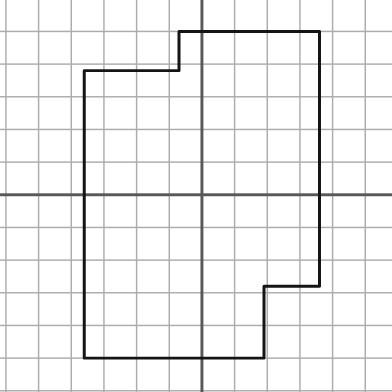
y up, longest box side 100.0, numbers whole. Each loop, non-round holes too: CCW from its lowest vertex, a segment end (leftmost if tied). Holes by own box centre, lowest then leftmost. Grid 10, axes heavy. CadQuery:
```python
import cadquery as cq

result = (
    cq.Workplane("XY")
    .moveTo(-36.0, -50.0)
    .lineTo(19.0, -50.0)
    .lineTo(19.0, -28.0)
    .lineTo(36.0, -28.0)
    .lineTo(36.0, 50.0)
    .lineTo(-7.0, 50.0)
    .lineTo(-7.0, 38.0)
    .lineTo(-36.0, 38.0)
    .close()
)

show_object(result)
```